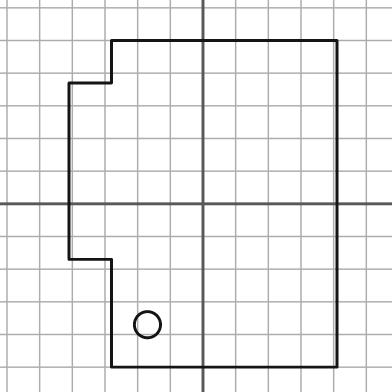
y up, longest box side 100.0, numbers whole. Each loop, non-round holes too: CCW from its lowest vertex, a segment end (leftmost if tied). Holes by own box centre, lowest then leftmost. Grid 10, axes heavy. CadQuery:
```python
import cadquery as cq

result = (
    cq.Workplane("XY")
    .moveTo(-28.0, -50.0)
    .lineTo(41.0, -50.0)
    .lineTo(41.0, 50.0)
    .lineTo(-28.0, 50.0)
    .lineTo(-28.0, 37.0)
    .lineTo(-41.0, 37.0)
    .lineTo(-41.0, -17.0)
    .lineTo(-28.0, -17.0)
    .close()
    .moveTo(-17.0, -37.0)
    .circle(4.0)
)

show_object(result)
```